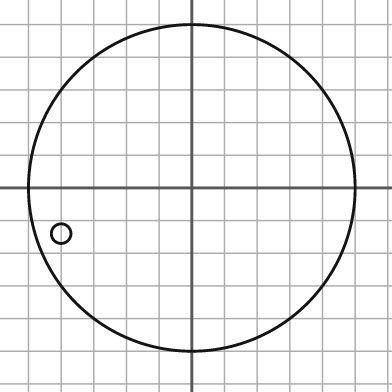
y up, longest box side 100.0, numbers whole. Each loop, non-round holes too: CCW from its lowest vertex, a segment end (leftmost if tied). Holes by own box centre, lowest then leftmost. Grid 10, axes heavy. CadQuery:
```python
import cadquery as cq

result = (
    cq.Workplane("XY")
    .moveTo(0.0, 0.0)
    .circle(50.0)
    .moveTo(-40.0, -14.0)
    .circle(3.0)
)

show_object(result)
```